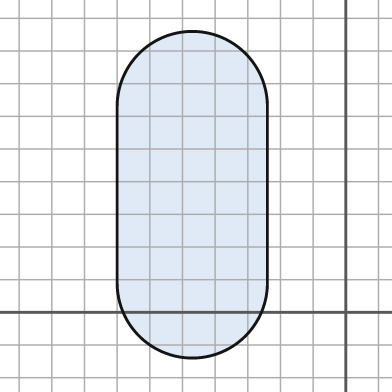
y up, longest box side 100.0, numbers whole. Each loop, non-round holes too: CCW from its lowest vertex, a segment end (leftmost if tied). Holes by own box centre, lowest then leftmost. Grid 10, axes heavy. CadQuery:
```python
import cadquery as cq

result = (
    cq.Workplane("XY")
    .moveTo(-70.0, 9.0)
    .threePointArc((-47.0, -14.0), (-24.0, 9.0))
    .lineTo(-24.0, 63.0)
    .threePointArc((-47.0, 86.0), (-70.0, 63.0))
    .close()
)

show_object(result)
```